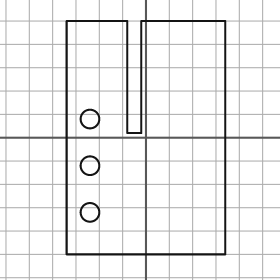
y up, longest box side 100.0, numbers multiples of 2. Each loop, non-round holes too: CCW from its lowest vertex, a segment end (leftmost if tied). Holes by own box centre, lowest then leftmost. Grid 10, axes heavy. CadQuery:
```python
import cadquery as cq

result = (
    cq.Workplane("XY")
    .moveTo(-34.0, -50.0)
    .lineTo(34.0, -50.0)
    .lineTo(34.0, 50.0)
    .lineTo(-2.0, 50.0)
    .lineTo(-2.0, 2.0)
    .lineTo(-8.0, 2.0)
    .lineTo(-8.0, 50.0)
    .lineTo(-34.0, 50.0)
    .close()
    .moveTo(-24.0, -32.0)
    .circle(4.0)
    .moveTo(-24.0, -12.0)
    .circle(4.0)
    .moveTo(-24.0, 8.0)
    .circle(4.0)
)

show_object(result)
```